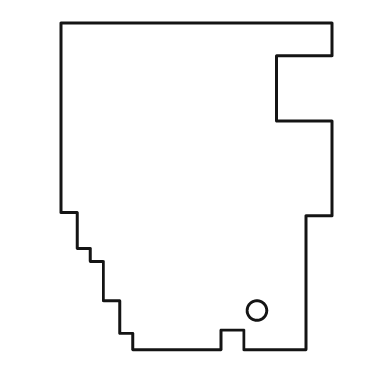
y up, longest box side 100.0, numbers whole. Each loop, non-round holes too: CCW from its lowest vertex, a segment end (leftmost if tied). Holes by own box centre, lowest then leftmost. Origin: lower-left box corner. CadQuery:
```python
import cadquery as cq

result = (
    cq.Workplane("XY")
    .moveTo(22.0, 0.0)
    .lineTo(49.0, 0.0)
    .lineTo(49.0, 6.0)
    .lineTo(56.0, 6.0)
    .lineTo(56.0, 0.0)
    .lineTo(75.0, 0.0)
    .lineTo(75.0, 41.0)
    .lineTo(83.0, 41.0)
    .lineTo(83.0, 70.0)
    .lineTo(66.0, 70.0)
    .lineTo(66.0, 90.0)
    .lineTo(83.0, 90.0)
    .lineTo(83.0, 100.0)
    .lineTo(0.0, 100.0)
    .lineTo(0.0, 42.0)
    .lineTo(5.0, 42.0)
    .lineTo(5.0, 31.0)
    .lineTo(9.0, 31.0)
    .lineTo(9.0, 27.0)
    .lineTo(13.0, 27.0)
    .lineTo(13.0, 15.0)
    .lineTo(18.0, 15.0)
    .lineTo(18.0, 5.0)
    .lineTo(22.0, 5.0)
    .close()
    .moveTo(60.0, 12.0)
    .circle(3.0)
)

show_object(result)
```